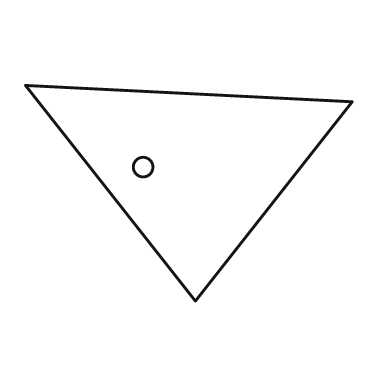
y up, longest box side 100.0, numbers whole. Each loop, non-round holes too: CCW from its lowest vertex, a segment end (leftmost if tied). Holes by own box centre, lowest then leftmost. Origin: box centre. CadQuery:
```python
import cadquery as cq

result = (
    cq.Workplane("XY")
    .moveTo(2.0, -33.0)
    .lineTo(50.0, 28.0)
    .lineTo(-50.0, 33.0)
    .close()
    .moveTo(-14.0, 8.0)
    .circle(3.0)
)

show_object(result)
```